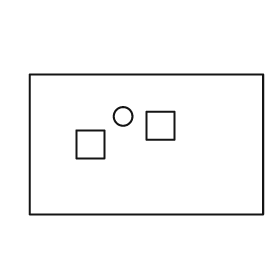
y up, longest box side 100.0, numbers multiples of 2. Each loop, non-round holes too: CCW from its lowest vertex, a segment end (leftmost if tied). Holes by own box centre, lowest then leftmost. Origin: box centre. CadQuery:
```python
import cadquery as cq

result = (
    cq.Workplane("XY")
    .moveTo(-50.0, -30.0)
    .lineTo(50.0, -30.0)
    .lineTo(50.0, 30.0)
    .lineTo(-50.0, 30.0)
    .close()
    .moveTo(-30.0, -6.0)
    .lineTo(-18.0, -6.0)
    .lineTo(-18.0, 6.0)
    .lineTo(-30.0, 6.0)
    .close()
    .moveTo(0.0, 2.0)
    .lineTo(12.0, 2.0)
    .lineTo(12.0, 14.0)
    .lineTo(0.0, 14.0)
    .close()
    .moveTo(-10.0, 12.0)
    .circle(4.0)
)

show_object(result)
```